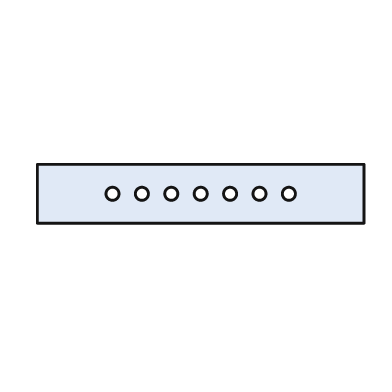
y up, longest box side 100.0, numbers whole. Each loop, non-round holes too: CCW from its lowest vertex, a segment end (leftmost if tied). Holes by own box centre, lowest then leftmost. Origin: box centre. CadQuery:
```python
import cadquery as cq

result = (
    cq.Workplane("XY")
    .moveTo(-50.0, -9.0)
    .lineTo(50.0, -9.0)
    .lineTo(50.0, 9.0)
    .lineTo(-50.0, 9.0)
    .close()
    .moveTo(-27.0, 0.0)
    .circle(2.0)
    .moveTo(-18.0, 0.0)
    .circle(2.0)
    .moveTo(-9.0, 0.0)
    .circle(2.0)
    .moveTo(0.0, 0.0)
    .circle(2.0)
    .moveTo(9.0, 0.0)
    .circle(2.0)
    .moveTo(18.0, 0.0)
    .circle(2.0)
    .moveTo(27.0, 0.0)
    .circle(2.0)
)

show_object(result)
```